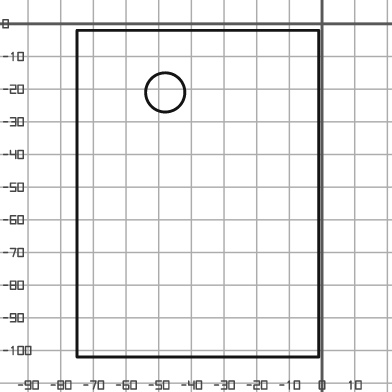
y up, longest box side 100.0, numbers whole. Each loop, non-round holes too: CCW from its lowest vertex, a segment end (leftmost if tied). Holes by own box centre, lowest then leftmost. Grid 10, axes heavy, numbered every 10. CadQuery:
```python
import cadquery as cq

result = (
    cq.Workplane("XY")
    .moveTo(-75.0, -102.0)
    .lineTo(-1.0, -102.0)
    .lineTo(-1.0, -2.0)
    .lineTo(-75.0, -2.0)
    .close()
    .moveTo(-48.0, -21.0)
    .circle(6.0)
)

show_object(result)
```